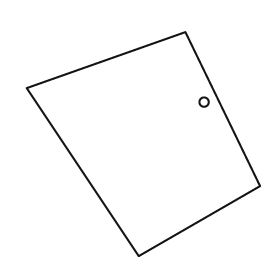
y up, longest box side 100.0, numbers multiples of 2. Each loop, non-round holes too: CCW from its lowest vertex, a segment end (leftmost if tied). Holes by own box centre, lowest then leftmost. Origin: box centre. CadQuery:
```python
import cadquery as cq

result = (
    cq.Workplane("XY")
    .moveTo(-2.0, -48.0)
    .lineTo(50.0, -18.0)
    .lineTo(18.0, 48.0)
    .lineTo(-50.0, 24.0)
    .close()
    .moveTo(26.0, 18.0)
    .circle(2.0)
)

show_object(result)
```